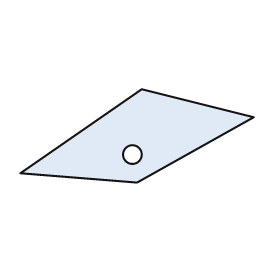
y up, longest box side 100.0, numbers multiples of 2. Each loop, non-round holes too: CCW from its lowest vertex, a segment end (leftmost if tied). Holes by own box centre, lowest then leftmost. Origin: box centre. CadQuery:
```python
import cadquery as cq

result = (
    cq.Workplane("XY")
    .moveTo(0.0, -20.0)
    .lineTo(50.0, 8.0)
    .lineTo(2.0, 20.0)
    .lineTo(-50.0, -16.0)
    .close()
    .moveTo(-2.0, -8.0)
    .circle(4.0)
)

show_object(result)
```